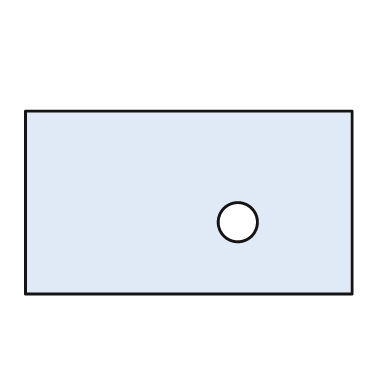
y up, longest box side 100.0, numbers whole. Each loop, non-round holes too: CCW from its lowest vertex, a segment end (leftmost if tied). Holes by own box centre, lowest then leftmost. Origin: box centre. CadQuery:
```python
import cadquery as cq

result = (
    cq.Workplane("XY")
    .moveTo(-50.0, -28.0)
    .lineTo(50.0, -28.0)
    .lineTo(50.0, 28.0)
    .lineTo(-50.0, 28.0)
    .close()
    .moveTo(15.0, -6.0)
    .circle(6.0)
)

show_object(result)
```